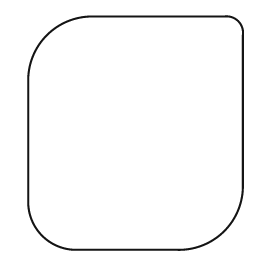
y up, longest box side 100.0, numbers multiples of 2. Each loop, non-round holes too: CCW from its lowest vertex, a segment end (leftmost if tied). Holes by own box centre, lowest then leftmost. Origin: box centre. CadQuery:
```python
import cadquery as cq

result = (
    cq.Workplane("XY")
    .moveTo(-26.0, -50.0)
    .lineTo(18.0, -50.0)
    .threePointArc((38.0, -42.0), (46.0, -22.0))
    .lineTo(46.0, 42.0)
    .threePointArc((44.0, 48.0), (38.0, 50.0))
    .lineTo(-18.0, 50.0)
    .threePointArc((-38.0, 42.0), (-46.0, 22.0))
    .lineTo(-46.0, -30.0)
    .threePointArc((-40.0, -44.0), (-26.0, -50.0))
    .close()
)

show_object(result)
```